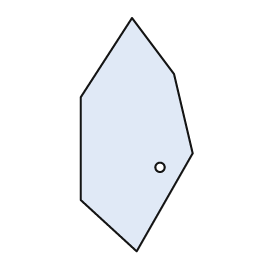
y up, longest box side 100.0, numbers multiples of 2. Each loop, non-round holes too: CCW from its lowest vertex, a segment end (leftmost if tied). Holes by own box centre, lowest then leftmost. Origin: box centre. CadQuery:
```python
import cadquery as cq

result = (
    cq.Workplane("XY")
    .moveTo(0.0, -50.0)
    .lineTo(24.0, -8.0)
    .lineTo(16.0, 26.0)
    .lineTo(-2.0, 50.0)
    .lineTo(-24.0, 16.0)
    .lineTo(-24.0, -28.0)
    .close()
    .moveTo(10.0, -14.0)
    .circle(2.0)
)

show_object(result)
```